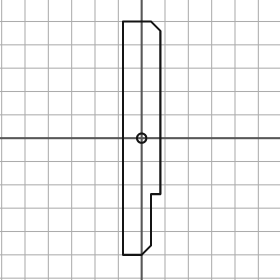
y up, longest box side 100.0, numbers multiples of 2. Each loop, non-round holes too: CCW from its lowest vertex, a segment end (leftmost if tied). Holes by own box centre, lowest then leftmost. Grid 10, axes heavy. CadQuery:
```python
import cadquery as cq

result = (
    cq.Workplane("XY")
    .moveTo(-8.0, -50.0)
    .lineTo(0.0, -50.0)
    .lineTo(4.0, -46.0)
    .lineTo(4.0, -24.0)
    .lineTo(8.0, -24.0)
    .lineTo(8.0, 46.0)
    .lineTo(4.0, 50.0)
    .lineTo(-8.0, 50.0)
    .close()
    .moveTo(0.0, 0.0)
    .circle(2.0)
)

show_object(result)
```